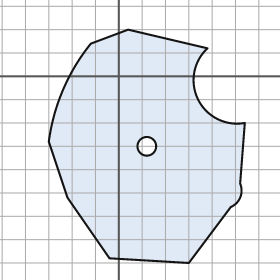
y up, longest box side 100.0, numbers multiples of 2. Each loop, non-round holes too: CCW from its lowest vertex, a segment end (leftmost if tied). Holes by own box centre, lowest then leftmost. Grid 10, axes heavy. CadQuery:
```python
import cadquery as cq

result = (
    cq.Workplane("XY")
    .moveTo(30.0, -80.0)
    .lineTo(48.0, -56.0)
    .threePointArc((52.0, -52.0), (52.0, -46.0))
    .lineTo(54.0, -20.0)
    .threePointArc((34.0, -10.0), (38.0, 12.0))
    .lineTo(4.0, 20.0)
    .lineTo(-12.0, 14.0)
    .threePointArc((-24.0, -6.0), (-30.0, -28.0))
    .lineTo(-22.0, -52.0)
    .lineTo(-4.0, -78.0)
    .close()
    .moveTo(12.0, -30.0)
    .circle(4.0)
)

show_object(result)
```